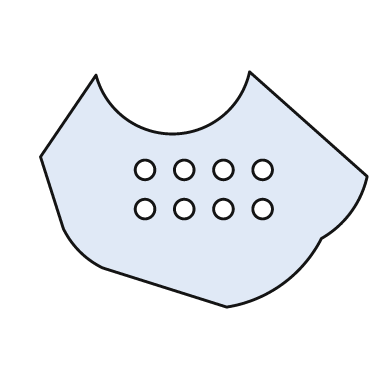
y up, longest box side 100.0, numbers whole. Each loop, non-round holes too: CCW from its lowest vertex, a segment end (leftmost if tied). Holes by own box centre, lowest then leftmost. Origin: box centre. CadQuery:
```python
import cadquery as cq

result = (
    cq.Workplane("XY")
    .moveTo(7.0, -36.0)
    .threePointArc((24.0, -29.0), (36.0, -15.0))
    .threePointArc((45.0, -7.0), (50.0, 4.0))
    .lineTo(14.0, 36.0)
    .threePointArc((-9.0, 17.0), (-33.0, 35.0))
    .lineTo(-50.0, 10.0)
    .lineTo(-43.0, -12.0)
    .threePointArc((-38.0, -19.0), (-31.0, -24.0))
    .close()
    .moveTo(-18.0, -6.0)
    .circle(3.0)
    .moveTo(-6.0, -6.0)
    .circle(3.0)
    .moveTo(6.0, -6.0)
    .circle(3.0)
    .moveTo(18.0, -6.0)
    .circle(3.0)
    .moveTo(-18.0, 6.0)
    .circle(3.0)
    .moveTo(-6.0, 6.0)
    .circle(3.0)
    .moveTo(6.0, 6.0)
    .circle(3.0)
    .moveTo(18.0, 6.0)
    .circle(3.0)
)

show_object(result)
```